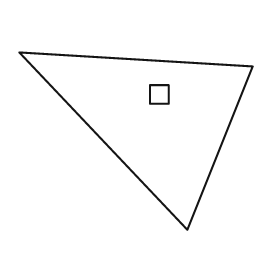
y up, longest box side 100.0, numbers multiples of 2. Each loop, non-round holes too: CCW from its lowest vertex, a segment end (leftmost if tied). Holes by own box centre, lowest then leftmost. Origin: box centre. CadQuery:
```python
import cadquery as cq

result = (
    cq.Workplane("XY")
    .moveTo(22.0, -38.0)
    .lineTo(50.0, 32.0)
    .lineTo(-50.0, 38.0)
    .close()
    .moveTo(6.0, 16.0)
    .lineTo(14.0, 16.0)
    .lineTo(14.0, 24.0)
    .lineTo(6.0, 24.0)
    .close()
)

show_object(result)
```